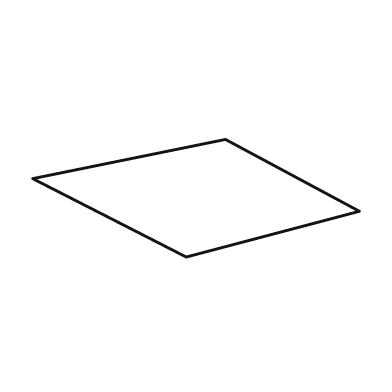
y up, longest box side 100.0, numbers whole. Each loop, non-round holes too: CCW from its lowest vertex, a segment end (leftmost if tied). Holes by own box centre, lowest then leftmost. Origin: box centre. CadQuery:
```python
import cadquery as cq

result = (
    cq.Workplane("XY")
    .moveTo(-3.0, -18.0)
    .lineTo(50.0, -4.0)
    .lineTo(9.0, 18.0)
    .lineTo(-50.0, 6.0)
    .close()
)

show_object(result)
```